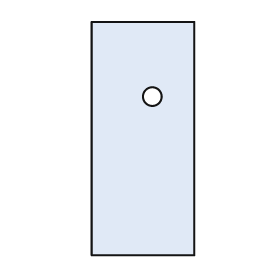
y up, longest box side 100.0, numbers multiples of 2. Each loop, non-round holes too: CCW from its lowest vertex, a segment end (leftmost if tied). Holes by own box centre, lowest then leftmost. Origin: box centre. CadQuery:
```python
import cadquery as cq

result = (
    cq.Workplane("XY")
    .moveTo(-22.0, -50.0)
    .lineTo(22.0, -50.0)
    .lineTo(22.0, 50.0)
    .lineTo(-22.0, 50.0)
    .close()
    .moveTo(4.0, 18.0)
    .circle(4.0)
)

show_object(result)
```